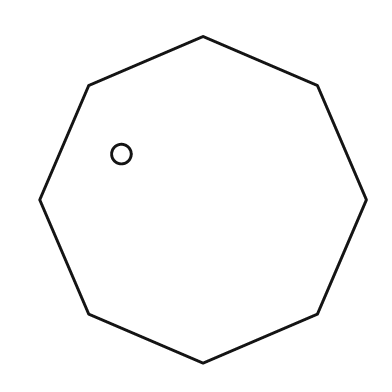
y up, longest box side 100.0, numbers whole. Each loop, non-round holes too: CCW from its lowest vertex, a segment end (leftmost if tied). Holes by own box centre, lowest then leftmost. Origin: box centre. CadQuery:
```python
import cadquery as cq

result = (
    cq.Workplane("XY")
    .moveTo(0.0, -50.0)
    .lineTo(35.0, -35.0)
    .lineTo(50.0, 0.0)
    .lineTo(35.0, 35.0)
    .lineTo(0.0, 50.0)
    .lineTo(-35.0, 35.0)
    .lineTo(-50.0, 0.0)
    .lineTo(-35.0, -35.0)
    .close()
    .moveTo(-25.0, 14.0)
    .circle(3.0)
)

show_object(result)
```